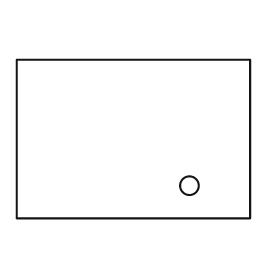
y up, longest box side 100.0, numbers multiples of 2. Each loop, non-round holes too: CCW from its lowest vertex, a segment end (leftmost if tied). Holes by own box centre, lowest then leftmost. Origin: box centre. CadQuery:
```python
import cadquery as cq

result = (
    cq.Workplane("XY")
    .moveTo(-50.0, -34.0)
    .lineTo(50.0, -34.0)
    .lineTo(50.0, 34.0)
    .lineTo(-50.0, 34.0)
    .close()
    .moveTo(24.0, -20.0)
    .circle(4.0)
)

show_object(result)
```